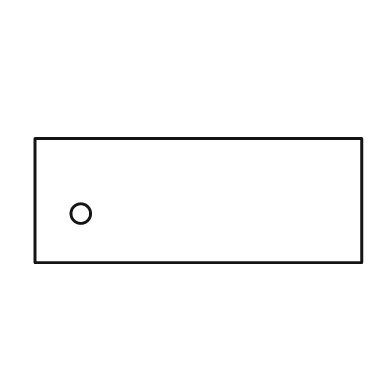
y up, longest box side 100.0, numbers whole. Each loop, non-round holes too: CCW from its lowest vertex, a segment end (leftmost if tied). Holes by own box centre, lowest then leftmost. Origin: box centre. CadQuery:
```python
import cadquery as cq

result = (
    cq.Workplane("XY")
    .moveTo(-50.0, -19.0)
    .lineTo(50.0, -19.0)
    .lineTo(50.0, 19.0)
    .lineTo(-50.0, 19.0)
    .close()
    .moveTo(-36.0, -4.0)
    .circle(3.0)
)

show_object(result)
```